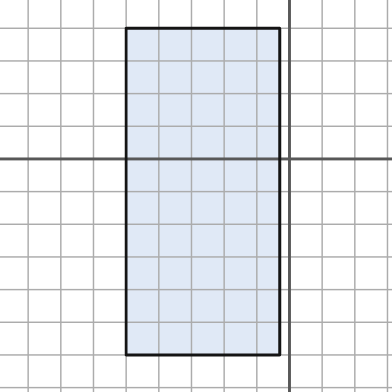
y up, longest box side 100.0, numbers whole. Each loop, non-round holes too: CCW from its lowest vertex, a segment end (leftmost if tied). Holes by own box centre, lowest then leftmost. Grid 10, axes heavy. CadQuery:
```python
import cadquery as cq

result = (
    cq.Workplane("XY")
    .moveTo(-50.0, -60.0)
    .lineTo(-3.0, -60.0)
    .lineTo(-3.0, 40.0)
    .lineTo(-50.0, 40.0)
    .close()
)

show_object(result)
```